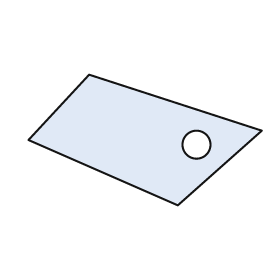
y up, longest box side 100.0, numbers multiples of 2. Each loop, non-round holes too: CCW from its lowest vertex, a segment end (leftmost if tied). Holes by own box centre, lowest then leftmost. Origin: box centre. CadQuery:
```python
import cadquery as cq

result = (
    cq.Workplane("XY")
    .moveTo(14.0, -28.0)
    .lineTo(50.0, 4.0)
    .lineTo(-24.0, 28.0)
    .lineTo(-50.0, 0.0)
    .close()
    .moveTo(22.0, -2.0)
    .circle(6.0)
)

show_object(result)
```